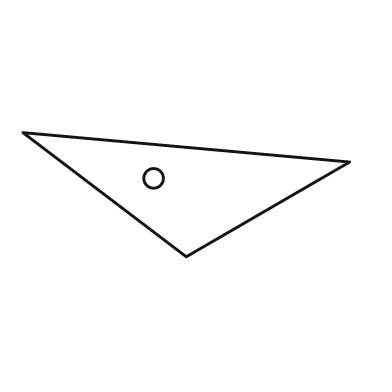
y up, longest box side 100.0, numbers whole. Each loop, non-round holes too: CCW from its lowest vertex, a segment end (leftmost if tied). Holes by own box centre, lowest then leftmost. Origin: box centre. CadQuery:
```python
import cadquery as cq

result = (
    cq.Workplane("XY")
    .moveTo(0.0, -19.0)
    .lineTo(50.0, 10.0)
    .lineTo(-50.0, 19.0)
    .close()
    .moveTo(-10.0, 5.0)
    .circle(3.0)
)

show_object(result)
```